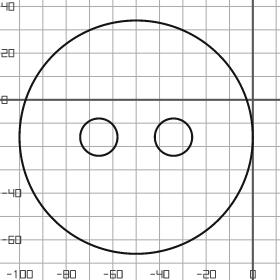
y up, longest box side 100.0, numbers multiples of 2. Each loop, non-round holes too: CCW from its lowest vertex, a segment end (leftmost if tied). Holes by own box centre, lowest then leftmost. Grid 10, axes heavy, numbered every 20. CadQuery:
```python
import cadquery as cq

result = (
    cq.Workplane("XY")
    .moveTo(-50.0, -16.0)
    .circle(50.0)
    .moveTo(-66.0, -16.0)
    .circle(8.0)
    .moveTo(-34.0, -16.0)
    .circle(8.0)
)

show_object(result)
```